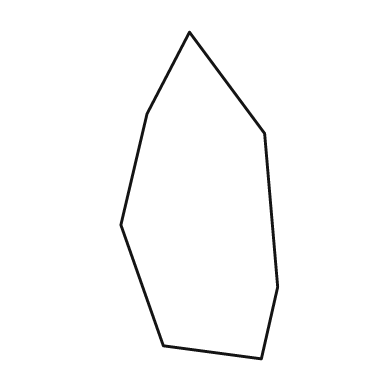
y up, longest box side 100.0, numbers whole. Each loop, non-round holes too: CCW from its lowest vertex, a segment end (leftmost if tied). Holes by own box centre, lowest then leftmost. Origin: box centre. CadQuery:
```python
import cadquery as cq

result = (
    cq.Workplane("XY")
    .moveTo(19.0, -50.0)
    .lineTo(24.0, -28.0)
    .lineTo(20.0, 19.0)
    .lineTo(-3.0, 50.0)
    .lineTo(-16.0, 25.0)
    .lineTo(-24.0, -9.0)
    .lineTo(-11.0, -46.0)
    .close()
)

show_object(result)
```